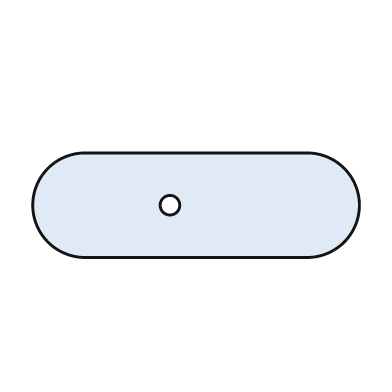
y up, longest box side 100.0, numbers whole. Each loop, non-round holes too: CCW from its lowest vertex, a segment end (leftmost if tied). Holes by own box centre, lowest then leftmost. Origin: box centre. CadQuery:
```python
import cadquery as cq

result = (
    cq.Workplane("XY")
    .moveTo(-34.0, -16.0)
    .lineTo(34.0, -16.0)
    .threePointArc((50.0, 0.0), (34.0, 16.0))
    .lineTo(-34.0, 16.0)
    .threePointArc((-50.0, 0.0), (-34.0, -16.0))
    .close()
    .moveTo(-8.0, 0.0)
    .circle(3.0)
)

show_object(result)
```